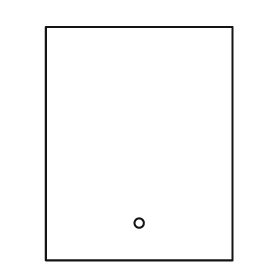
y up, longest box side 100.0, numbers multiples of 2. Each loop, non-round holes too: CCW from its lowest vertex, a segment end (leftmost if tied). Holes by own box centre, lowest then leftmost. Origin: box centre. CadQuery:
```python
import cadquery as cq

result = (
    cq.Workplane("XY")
    .moveTo(-40.0, -50.0)
    .lineTo(40.0, -50.0)
    .lineTo(40.0, 50.0)
    .lineTo(-40.0, 50.0)
    .close()
    .moveTo(0.0, -34.0)
    .circle(2.0)
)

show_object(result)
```